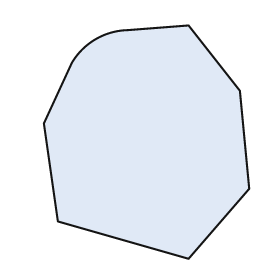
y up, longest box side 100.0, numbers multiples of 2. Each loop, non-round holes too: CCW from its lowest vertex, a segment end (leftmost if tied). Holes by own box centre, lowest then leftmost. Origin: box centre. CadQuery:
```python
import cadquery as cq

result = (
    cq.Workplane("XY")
    .moveTo(18.0, -50.0)
    .lineTo(44.0, -20.0)
    .lineTo(40.0, 22.0)
    .lineTo(18.0, 50.0)
    .lineTo(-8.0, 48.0)
    .threePointArc((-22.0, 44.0), (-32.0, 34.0))
    .lineTo(-44.0, 8.0)
    .lineTo(-38.0, -34.0)
    .close()
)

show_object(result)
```